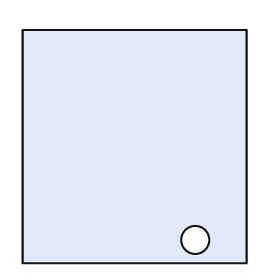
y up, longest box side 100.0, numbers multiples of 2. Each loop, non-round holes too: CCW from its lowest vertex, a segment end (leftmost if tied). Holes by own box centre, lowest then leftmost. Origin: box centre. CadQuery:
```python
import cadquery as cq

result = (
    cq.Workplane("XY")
    .moveTo(-48.0, -50.0)
    .lineTo(48.0, -50.0)
    .lineTo(48.0, 50.0)
    .lineTo(-48.0, 50.0)
    .close()
    .moveTo(26.0, -40.0)
    .circle(6.0)
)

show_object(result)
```